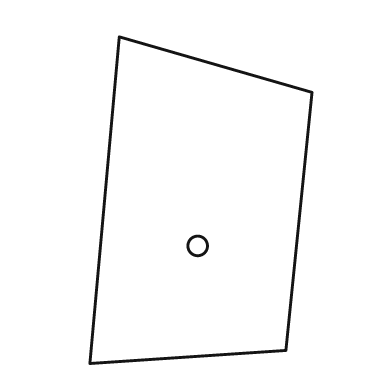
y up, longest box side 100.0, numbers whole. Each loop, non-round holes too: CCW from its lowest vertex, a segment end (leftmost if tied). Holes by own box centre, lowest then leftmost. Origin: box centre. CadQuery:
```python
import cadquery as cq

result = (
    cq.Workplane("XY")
    .moveTo(-34.0, -50.0)
    .lineTo(26.0, -46.0)
    .lineTo(34.0, 33.0)
    .lineTo(-25.0, 50.0)
    .close()
    .moveTo(-1.0, -14.0)
    .circle(3.0)
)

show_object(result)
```